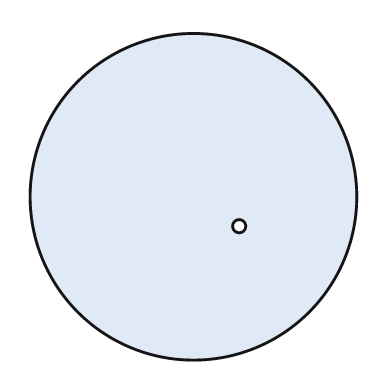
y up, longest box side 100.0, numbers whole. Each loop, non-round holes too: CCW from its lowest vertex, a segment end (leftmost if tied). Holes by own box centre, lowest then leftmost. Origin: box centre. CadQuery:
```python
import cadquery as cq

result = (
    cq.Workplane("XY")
    .moveTo(0.0, 0.0)
    .circle(50.0)
    .moveTo(14.0, -9.0)
    .circle(2.0)
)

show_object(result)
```